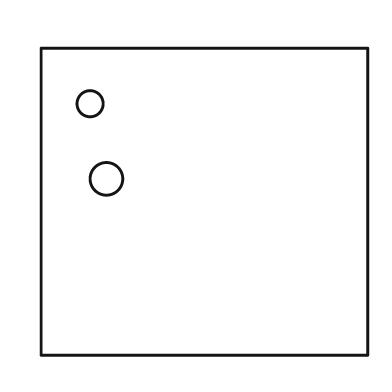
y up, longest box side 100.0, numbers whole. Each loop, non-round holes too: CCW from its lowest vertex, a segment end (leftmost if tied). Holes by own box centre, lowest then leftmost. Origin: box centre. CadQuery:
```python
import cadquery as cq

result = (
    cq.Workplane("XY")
    .moveTo(-50.0, -47.0)
    .lineTo(50.0, -47.0)
    .lineTo(50.0, 47.0)
    .lineTo(-50.0, 47.0)
    .close()
    .moveTo(-30.0, 7.0)
    .circle(5.0)
    .moveTo(-35.0, 30.0)
    .circle(4.0)
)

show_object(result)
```